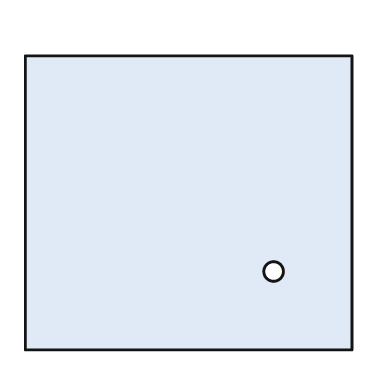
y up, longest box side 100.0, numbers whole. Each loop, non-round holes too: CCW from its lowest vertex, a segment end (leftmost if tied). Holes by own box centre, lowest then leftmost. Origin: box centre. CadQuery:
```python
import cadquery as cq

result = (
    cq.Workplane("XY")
    .moveTo(-50.0, -45.0)
    .lineTo(50.0, -45.0)
    .lineTo(50.0, 45.0)
    .lineTo(-50.0, 45.0)
    .close()
    .moveTo(26.0, -21.0)
    .circle(3.0)
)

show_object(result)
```